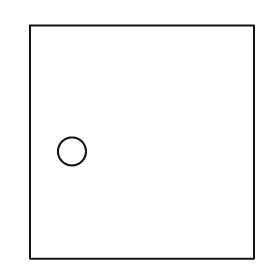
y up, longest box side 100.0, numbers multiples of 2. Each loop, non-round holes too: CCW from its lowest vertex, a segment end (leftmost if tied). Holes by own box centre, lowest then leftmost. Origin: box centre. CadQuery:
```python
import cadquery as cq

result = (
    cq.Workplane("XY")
    .moveTo(-48.0, -50.0)
    .lineTo(48.0, -50.0)
    .lineTo(48.0, 50.0)
    .lineTo(-48.0, 50.0)
    .close()
    .moveTo(-30.0, -4.0)
    .circle(6.0)
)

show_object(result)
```